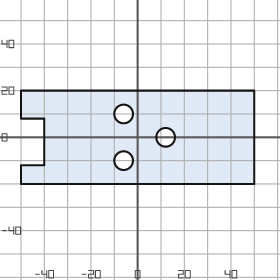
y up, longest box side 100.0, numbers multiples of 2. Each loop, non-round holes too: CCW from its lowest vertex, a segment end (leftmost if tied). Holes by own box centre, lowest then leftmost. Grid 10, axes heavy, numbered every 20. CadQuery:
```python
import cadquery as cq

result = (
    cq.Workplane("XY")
    .moveTo(-50.0, -20.0)
    .lineTo(50.0, -20.0)
    .lineTo(50.0, 20.0)
    .lineTo(-50.0, 20.0)
    .lineTo(-50.0, 8.0)
    .lineTo(-40.0, 8.0)
    .lineTo(-40.0, -12.0)
    .lineTo(-50.0, -12.0)
    .close()
    .moveTo(-6.0, -10.0)
    .circle(4.0)
    .moveTo(12.0, 0.0)
    .circle(4.0)
    .moveTo(-6.0, 10.0)
    .circle(4.0)
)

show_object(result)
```